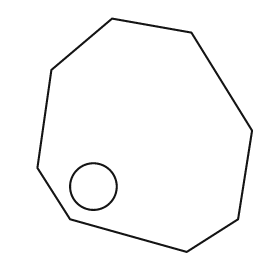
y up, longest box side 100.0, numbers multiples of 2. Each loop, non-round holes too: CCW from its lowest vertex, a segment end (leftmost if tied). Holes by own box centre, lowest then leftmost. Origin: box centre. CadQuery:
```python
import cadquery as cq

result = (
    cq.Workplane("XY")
    .moveTo(18.0, -50.0)
    .lineTo(40.0, -36.0)
    .lineTo(46.0, 2.0)
    .lineTo(20.0, 44.0)
    .lineTo(-14.0, 50.0)
    .lineTo(-40.0, 28.0)
    .lineTo(-46.0, -14.0)
    .lineTo(-32.0, -36.0)
    .close()
    .moveTo(-22.0, -22.0)
    .circle(10.0)
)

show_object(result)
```